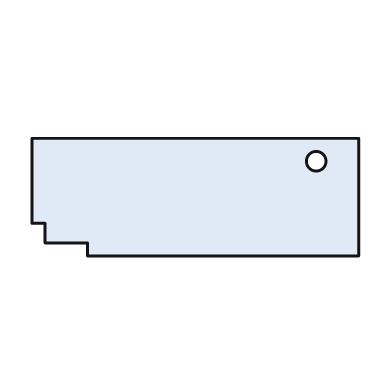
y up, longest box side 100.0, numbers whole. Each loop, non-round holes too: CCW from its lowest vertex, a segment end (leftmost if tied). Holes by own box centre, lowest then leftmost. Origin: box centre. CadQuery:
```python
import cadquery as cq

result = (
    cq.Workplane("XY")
    .moveTo(-33.0, -18.0)
    .lineTo(50.0, -18.0)
    .lineTo(50.0, 18.0)
    .lineTo(-50.0, 18.0)
    .lineTo(-50.0, -8.0)
    .lineTo(-46.0, -8.0)
    .lineTo(-46.0, -14.0)
    .lineTo(-33.0, -14.0)
    .close()
    .moveTo(37.0, 11.0)
    .circle(3.0)
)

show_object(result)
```